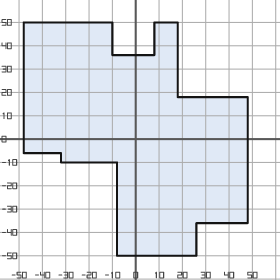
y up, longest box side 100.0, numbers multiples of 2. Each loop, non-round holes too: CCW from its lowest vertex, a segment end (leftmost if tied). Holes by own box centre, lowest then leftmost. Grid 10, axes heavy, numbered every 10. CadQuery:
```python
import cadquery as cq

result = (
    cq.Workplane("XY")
    .moveTo(-8.0, -50.0)
    .lineTo(26.0, -50.0)
    .lineTo(26.0, -36.0)
    .lineTo(48.0, -36.0)
    .lineTo(48.0, 18.0)
    .lineTo(18.0, 18.0)
    .lineTo(18.0, 50.0)
    .lineTo(8.0, 50.0)
    .lineTo(8.0, 36.0)
    .lineTo(-10.0, 36.0)
    .lineTo(-10.0, 50.0)
    .lineTo(-48.0, 50.0)
    .lineTo(-48.0, -6.0)
    .lineTo(-32.0, -6.0)
    .lineTo(-32.0, -10.0)
    .lineTo(-8.0, -10.0)
    .close()
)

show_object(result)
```